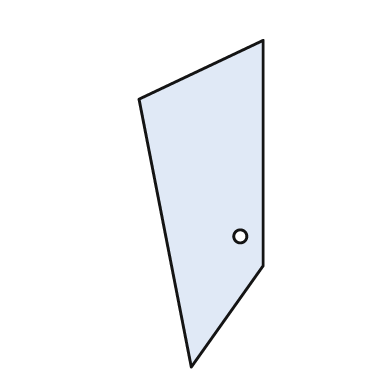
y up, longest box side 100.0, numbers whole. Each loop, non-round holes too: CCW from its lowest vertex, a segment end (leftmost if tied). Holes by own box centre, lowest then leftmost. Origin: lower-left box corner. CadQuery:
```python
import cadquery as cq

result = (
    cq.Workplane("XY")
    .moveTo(16.0, 0.0)
    .lineTo(38.0, 31.0)
    .lineTo(38.0, 100.0)
    .lineTo(0.0, 82.0)
    .close()
    .moveTo(31.0, 40.0)
    .circle(2.0)
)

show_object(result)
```